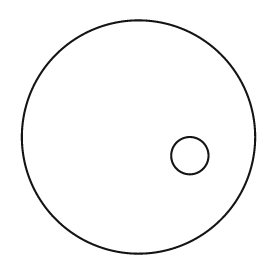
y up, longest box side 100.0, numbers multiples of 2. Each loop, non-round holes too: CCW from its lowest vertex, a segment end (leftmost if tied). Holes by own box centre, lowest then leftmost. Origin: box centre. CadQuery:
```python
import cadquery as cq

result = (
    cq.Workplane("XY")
    .moveTo(0.0, 0.0)
    .circle(50.0)
    .moveTo(22.0, -8.0)
    .circle(8.0)
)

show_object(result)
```